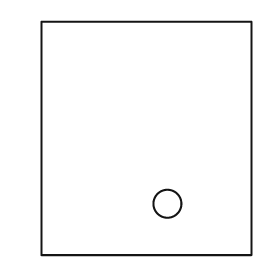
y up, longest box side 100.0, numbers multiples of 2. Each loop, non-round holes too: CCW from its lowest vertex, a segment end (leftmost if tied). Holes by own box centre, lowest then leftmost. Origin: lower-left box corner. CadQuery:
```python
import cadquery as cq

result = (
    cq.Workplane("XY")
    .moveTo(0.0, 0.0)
    .lineTo(90.0, 0.0)
    .lineTo(90.0, 100.0)
    .lineTo(0.0, 100.0)
    .close()
    .moveTo(54.0, 22.0)
    .circle(6.0)
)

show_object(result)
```